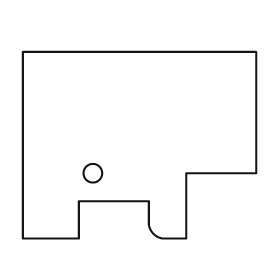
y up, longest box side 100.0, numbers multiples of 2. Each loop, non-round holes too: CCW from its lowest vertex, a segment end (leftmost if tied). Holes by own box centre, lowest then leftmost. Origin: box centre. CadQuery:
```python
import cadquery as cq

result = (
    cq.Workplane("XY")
    .moveTo(-50.0, -40.0)
    .lineTo(-26.0, -40.0)
    .lineTo(-26.0, -24.0)
    .lineTo(4.0, -24.0)
    .lineTo(4.0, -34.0)
    .threePointArc((6.0, -38.0), (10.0, -40.0))
    .lineTo(20.0, -40.0)
    .lineTo(20.0, -12.0)
    .lineTo(50.0, -12.0)
    .lineTo(50.0, 40.0)
    .lineTo(-50.0, 40.0)
    .close()
    .moveTo(-20.0, -12.0)
    .circle(4.0)
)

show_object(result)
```